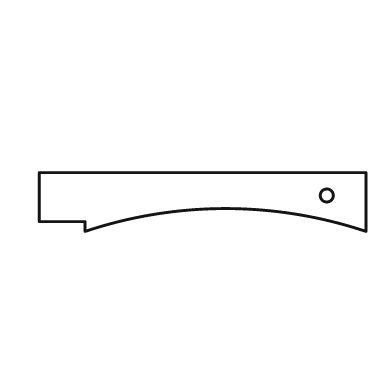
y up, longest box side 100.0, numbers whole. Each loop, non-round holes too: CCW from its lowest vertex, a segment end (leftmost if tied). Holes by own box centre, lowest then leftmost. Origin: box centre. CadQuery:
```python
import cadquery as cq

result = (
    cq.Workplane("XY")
    .moveTo(-36.0, -9.0)
    .threePointArc((7.0, -2.0), (50.0, -9.0))
    .lineTo(50.0, 9.0)
    .lineTo(-50.0, 9.0)
    .lineTo(-50.0, -6.0)
    .lineTo(-36.0, -6.0)
    .close()
    .moveTo(38.0, 2.0)
    .circle(2.0)
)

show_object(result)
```